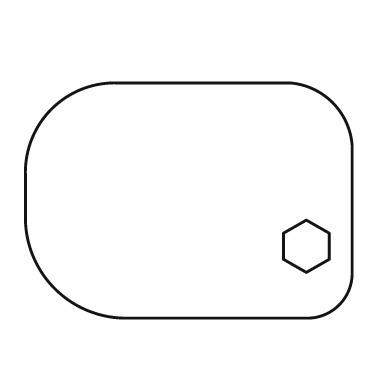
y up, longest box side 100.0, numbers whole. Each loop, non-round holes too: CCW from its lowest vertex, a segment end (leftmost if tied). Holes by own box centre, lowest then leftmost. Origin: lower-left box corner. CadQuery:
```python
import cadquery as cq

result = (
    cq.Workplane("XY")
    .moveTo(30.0, 0.0)
    .lineTo(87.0, 0.0)
    .threePointArc((96.0, 4.0), (100.0, 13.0))
    .lineTo(100.0, 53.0)
    .threePointArc((94.0, 66.0), (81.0, 72.0))
    .lineTo(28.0, 72.0)
    .threePointArc((8.0, 64.0), (0.0, 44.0))
    .lineTo(0.0, 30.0)
    .threePointArc((9.0, 9.0), (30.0, 0.0))
    .close()
    .moveTo(86.0, 14.0)
    .lineTo(93.0, 18.0)
    .lineTo(93.0, 26.0)
    .lineTo(86.0, 30.0)
    .lineTo(79.0, 26.0)
    .lineTo(79.0, 18.0)
    .close()
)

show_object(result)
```